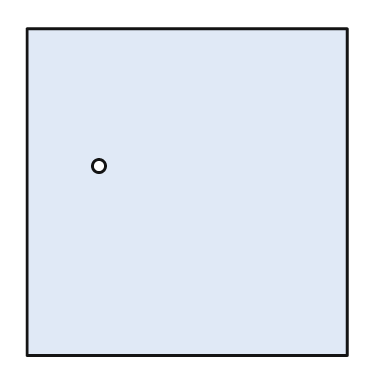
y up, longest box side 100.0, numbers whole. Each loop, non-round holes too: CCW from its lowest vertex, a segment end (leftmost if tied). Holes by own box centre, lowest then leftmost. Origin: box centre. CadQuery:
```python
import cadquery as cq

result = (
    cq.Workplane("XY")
    .moveTo(-49.0, -50.0)
    .lineTo(49.0, -50.0)
    .lineTo(49.0, 50.0)
    .lineTo(-49.0, 50.0)
    .close()
    .moveTo(-27.0, 8.0)
    .circle(2.0)
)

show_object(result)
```